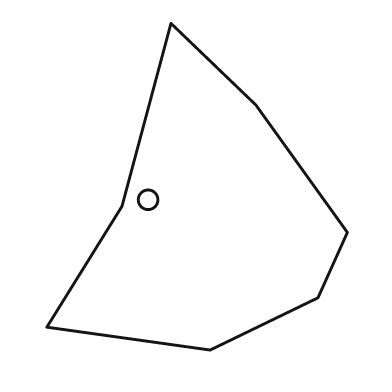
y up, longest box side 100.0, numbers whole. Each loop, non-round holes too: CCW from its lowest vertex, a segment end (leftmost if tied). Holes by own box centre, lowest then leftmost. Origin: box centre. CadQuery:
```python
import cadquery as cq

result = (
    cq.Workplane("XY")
    .moveTo(4.0, -50.0)
    .lineTo(37.0, -34.0)
    .lineTo(46.0, -14.0)
    .lineTo(18.0, 25.0)
    .lineTo(-8.0, 50.0)
    .lineTo(-23.0, -6.0)
    .lineTo(-46.0, -43.0)
    .close()
    .moveTo(-15.0, -4.0)
    .circle(3.0)
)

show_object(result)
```